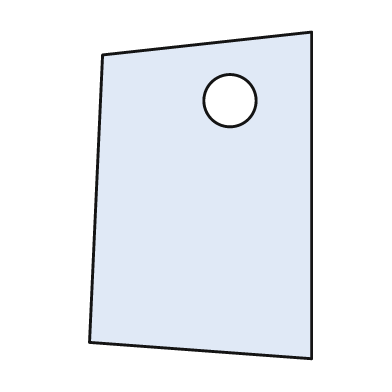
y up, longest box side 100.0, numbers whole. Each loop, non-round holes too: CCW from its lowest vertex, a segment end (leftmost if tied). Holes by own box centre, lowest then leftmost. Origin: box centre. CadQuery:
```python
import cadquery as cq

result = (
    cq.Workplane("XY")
    .moveTo(34.0, -50.0)
    .lineTo(34.0, 50.0)
    .lineTo(-30.0, 43.0)
    .lineTo(-34.0, -45.0)
    .close()
    .moveTo(9.0, 29.0)
    .circle(8.0)
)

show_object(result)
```